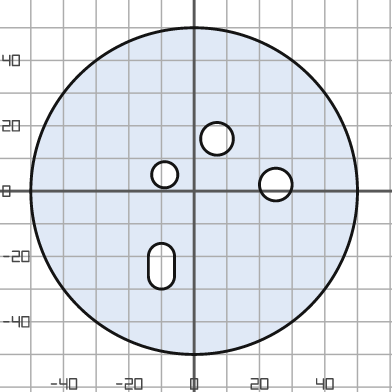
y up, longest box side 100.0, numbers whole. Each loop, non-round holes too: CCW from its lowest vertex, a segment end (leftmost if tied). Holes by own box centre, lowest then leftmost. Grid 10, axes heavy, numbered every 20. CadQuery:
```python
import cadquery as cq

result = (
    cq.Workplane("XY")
    .moveTo(0.0, 0.0)
    .circle(50.0)
    .moveTo(-14.0, -26.0)
    .threePointArc((-10.0, -30.0), (-6.0, -26.0))
    .lineTo(-6.0, -20.0)
    .threePointArc((-10.0, -16.0), (-14.0, -20.0))
    .close()
    .moveTo(25.0, 2.0)
    .circle(5.0)
    .moveTo(-9.0, 5.0)
    .circle(4.0)
    .moveTo(7.0, 16.0)
    .circle(5.0)
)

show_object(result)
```